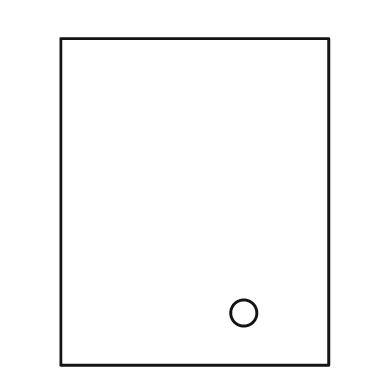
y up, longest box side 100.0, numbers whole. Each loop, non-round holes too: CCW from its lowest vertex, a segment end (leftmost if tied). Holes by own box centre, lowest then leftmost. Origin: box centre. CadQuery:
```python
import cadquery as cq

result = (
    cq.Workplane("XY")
    .moveTo(-41.0, -50.0)
    .lineTo(41.0, -50.0)
    .lineTo(41.0, 50.0)
    .lineTo(-41.0, 50.0)
    .close()
    .moveTo(15.0, -34.0)
    .circle(4.0)
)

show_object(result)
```